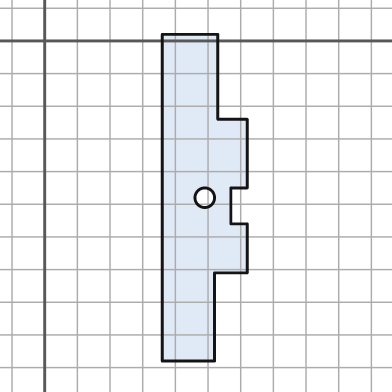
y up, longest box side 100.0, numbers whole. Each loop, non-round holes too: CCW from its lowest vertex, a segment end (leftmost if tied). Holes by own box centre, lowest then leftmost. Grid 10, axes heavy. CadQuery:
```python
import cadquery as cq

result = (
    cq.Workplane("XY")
    .moveTo(36.0, -98.0)
    .lineTo(52.0, -98.0)
    .lineTo(52.0, -71.0)
    .lineTo(62.0, -71.0)
    .lineTo(62.0, -56.0)
    .lineTo(57.0, -56.0)
    .lineTo(57.0, -45.0)
    .lineTo(62.0, -45.0)
    .lineTo(62.0, -24.0)
    .lineTo(53.0, -24.0)
    .lineTo(53.0, 2.0)
    .lineTo(36.0, 2.0)
    .close()
    .moveTo(49.0, -48.0)
    .circle(3.0)
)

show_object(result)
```